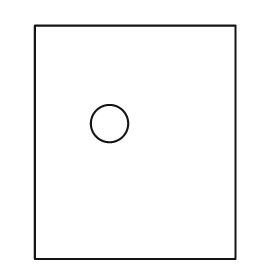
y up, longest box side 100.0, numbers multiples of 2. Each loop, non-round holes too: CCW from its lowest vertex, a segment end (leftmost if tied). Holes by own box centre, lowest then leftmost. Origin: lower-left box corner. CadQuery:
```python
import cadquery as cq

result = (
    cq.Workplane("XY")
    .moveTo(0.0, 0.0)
    .lineTo(86.0, 0.0)
    .lineTo(86.0, 100.0)
    .lineTo(0.0, 100.0)
    .close()
    .moveTo(32.0, 58.0)
    .circle(8.0)
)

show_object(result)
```